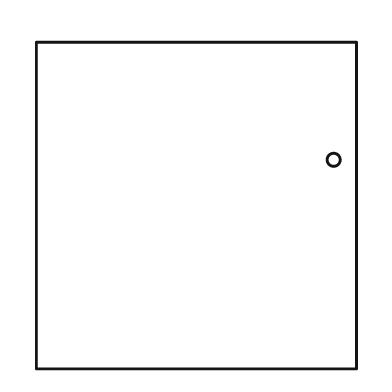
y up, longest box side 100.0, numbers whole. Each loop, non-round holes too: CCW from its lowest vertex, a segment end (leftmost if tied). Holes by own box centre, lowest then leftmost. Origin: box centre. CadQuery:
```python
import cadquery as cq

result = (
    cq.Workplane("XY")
    .moveTo(-49.0, -50.0)
    .lineTo(49.0, -50.0)
    .lineTo(49.0, 50.0)
    .lineTo(-49.0, 50.0)
    .close()
    .moveTo(42.0, 14.0)
    .circle(2.0)
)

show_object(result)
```